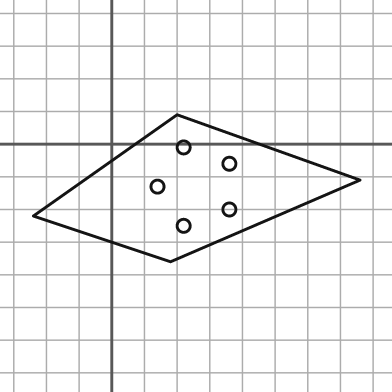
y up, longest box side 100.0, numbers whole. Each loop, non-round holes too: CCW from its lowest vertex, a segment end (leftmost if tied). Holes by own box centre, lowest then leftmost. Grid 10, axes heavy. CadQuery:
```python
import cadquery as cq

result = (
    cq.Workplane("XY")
    .moveTo(18.0, -36.0)
    .lineTo(76.0, -11.0)
    .lineTo(20.0, 9.0)
    .lineTo(-24.0, -22.0)
    .close()
    .moveTo(22.0, -25.0)
    .circle(2.0)
    .moveTo(36.0, -20.0)
    .circle(2.0)
    .moveTo(14.0, -13.0)
    .circle(2.0)
    .moveTo(36.0, -6.0)
    .circle(2.0)
    .moveTo(22.0, -1.0)
    .circle(2.0)
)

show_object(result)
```